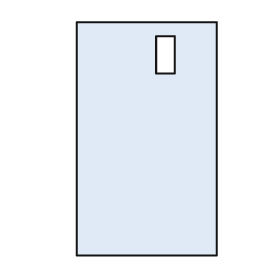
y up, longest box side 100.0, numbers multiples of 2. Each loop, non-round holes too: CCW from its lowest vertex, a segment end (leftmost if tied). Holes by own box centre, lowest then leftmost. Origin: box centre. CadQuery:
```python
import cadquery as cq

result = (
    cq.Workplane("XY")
    .moveTo(-30.0, -50.0)
    .lineTo(30.0, -50.0)
    .lineTo(30.0, 50.0)
    .lineTo(-30.0, 50.0)
    .close()
    .moveTo(4.0, 28.0)
    .lineTo(12.0, 28.0)
    .lineTo(12.0, 44.0)
    .lineTo(4.0, 44.0)
    .close()
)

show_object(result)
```